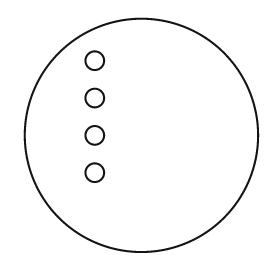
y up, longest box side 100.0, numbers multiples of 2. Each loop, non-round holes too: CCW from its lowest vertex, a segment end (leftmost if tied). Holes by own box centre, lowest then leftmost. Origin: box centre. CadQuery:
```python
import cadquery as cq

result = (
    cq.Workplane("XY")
    .moveTo(0.0, 0.0)
    .circle(50.0)
    .moveTo(-20.0, -16.0)
    .circle(4.0)
    .moveTo(-20.0, 0.0)
    .circle(4.0)
    .moveTo(-20.0, 16.0)
    .circle(4.0)
    .moveTo(-20.0, 32.0)
    .circle(4.0)
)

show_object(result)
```